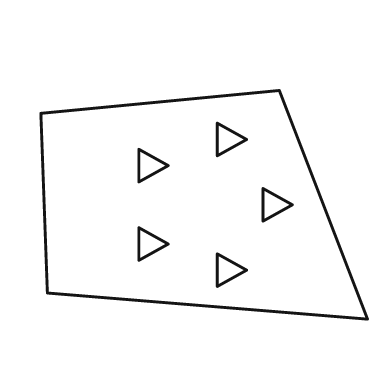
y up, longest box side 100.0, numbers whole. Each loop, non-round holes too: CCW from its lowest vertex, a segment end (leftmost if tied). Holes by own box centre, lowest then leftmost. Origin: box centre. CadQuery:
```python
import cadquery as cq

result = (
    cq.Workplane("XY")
    .moveTo(50.0, -35.0)
    .lineTo(23.0, 35.0)
    .lineTo(-50.0, 28.0)
    .lineTo(-48.0, -27.0)
    .close()
    .moveTo(4.0, -25.0)
    .lineTo(13.0, -20.0)
    .lineTo(4.0, -15.0)
    .close()
    .moveTo(-20.0, -17.0)
    .lineTo(-11.0, -12.0)
    .lineTo(-20.0, -7.0)
    .close()
    .moveTo(18.0, -5.0)
    .lineTo(27.0, 0.0)
    .lineTo(18.0, 5.0)
    .close()
    .moveTo(-20.0, 7.0)
    .lineTo(-11.0, 12.0)
    .lineTo(-20.0, 17.0)
    .close()
    .moveTo(4.0, 15.0)
    .lineTo(13.0, 20.0)
    .lineTo(4.0, 25.0)
    .close()
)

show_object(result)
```